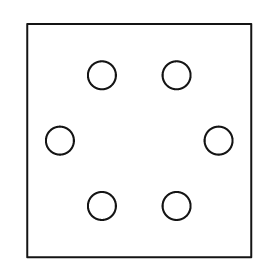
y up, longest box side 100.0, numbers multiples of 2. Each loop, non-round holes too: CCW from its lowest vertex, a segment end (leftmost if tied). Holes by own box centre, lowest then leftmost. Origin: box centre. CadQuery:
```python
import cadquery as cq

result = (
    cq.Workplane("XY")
    .moveTo(-48.0, -50.0)
    .lineTo(48.0, -50.0)
    .lineTo(48.0, 50.0)
    .lineTo(-48.0, 50.0)
    .close()
    .moveTo(-16.0, -28.0)
    .circle(6.0)
    .moveTo(16.0, -28.0)
    .circle(6.0)
    .moveTo(-34.0, 0.0)
    .circle(6.0)
    .moveTo(34.0, 0.0)
    .circle(6.0)
    .moveTo(-16.0, 28.0)
    .circle(6.0)
    .moveTo(16.0, 28.0)
    .circle(6.0)
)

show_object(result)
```